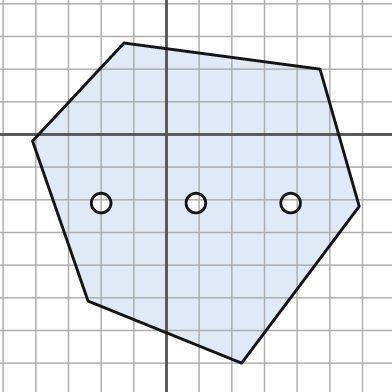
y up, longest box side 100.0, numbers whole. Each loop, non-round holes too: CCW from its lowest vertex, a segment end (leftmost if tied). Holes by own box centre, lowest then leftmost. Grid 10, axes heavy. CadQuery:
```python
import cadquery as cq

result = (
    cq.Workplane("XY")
    .moveTo(23.0, -70.0)
    .lineTo(59.0, -22.0)
    .lineTo(47.0, 20.0)
    .lineTo(-13.0, 28.0)
    .lineTo(-41.0, -2.0)
    .lineTo(-24.0, -51.0)
    .close()
    .moveTo(-20.0, -21.0)
    .circle(3.0)
    .moveTo(9.0, -21.0)
    .circle(3.0)
    .moveTo(38.0, -21.0)
    .circle(3.0)
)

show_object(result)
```